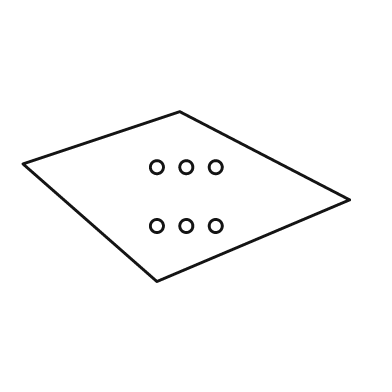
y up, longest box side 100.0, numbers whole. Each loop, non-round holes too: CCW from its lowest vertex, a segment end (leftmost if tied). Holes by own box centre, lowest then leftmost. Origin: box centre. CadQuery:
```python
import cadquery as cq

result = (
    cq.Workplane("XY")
    .moveTo(-9.0, -26.0)
    .lineTo(50.0, -1.0)
    .lineTo(-2.0, 26.0)
    .lineTo(-50.0, 10.0)
    .close()
    .moveTo(-9.0, -9.0)
    .circle(2.0)
    .moveTo(0.0, -9.0)
    .circle(2.0)
    .moveTo(9.0, -9.0)
    .circle(2.0)
    .moveTo(-9.0, 9.0)
    .circle(2.0)
    .moveTo(0.0, 9.0)
    .circle(2.0)
    .moveTo(9.0, 9.0)
    .circle(2.0)
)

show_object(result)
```